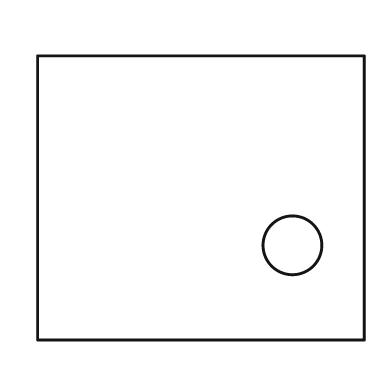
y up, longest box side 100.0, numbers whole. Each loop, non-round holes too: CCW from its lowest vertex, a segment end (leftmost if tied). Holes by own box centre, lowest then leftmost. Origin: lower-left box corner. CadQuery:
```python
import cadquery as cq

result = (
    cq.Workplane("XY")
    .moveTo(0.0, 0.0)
    .lineTo(100.0, 0.0)
    .lineTo(100.0, 87.0)
    .lineTo(0.0, 87.0)
    .close()
    .moveTo(78.0, 29.0)
    .circle(9.0)
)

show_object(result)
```